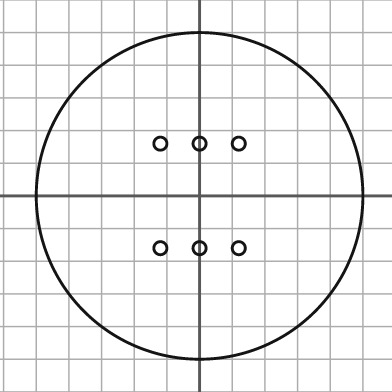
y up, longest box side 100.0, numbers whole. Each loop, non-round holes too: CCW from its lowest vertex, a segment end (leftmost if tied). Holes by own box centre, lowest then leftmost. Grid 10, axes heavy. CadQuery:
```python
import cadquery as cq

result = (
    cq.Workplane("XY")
    .moveTo(0.0, 0.0)
    .circle(50.0)
    .moveTo(-12.0, -16.0)
    .circle(2.0)
    .moveTo(0.0, -16.0)
    .circle(2.0)
    .moveTo(12.0, -16.0)
    .circle(2.0)
    .moveTo(-12.0, 16.0)
    .circle(2.0)
    .moveTo(0.0, 16.0)
    .circle(2.0)
    .moveTo(12.0, 16.0)
    .circle(2.0)
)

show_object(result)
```